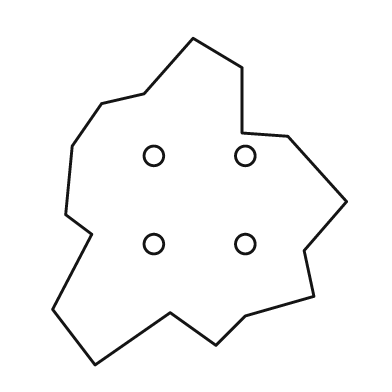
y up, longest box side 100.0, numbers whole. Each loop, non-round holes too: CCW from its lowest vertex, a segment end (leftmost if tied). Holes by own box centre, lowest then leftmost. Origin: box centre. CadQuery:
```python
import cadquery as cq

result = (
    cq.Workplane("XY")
    .moveTo(-32.0, -50.0)
    .lineTo(-9.0, -34.0)
    .lineTo(5.0, -44.0)
    .lineTo(14.0, -35.0)
    .lineTo(35.0, -29.0)
    .lineTo(32.0, -15.0)
    .lineTo(45.0, 0.0)
    .lineTo(27.0, 20.0)
    .lineTo(13.0, 21.0)
    .lineTo(13.0, 41.0)
    .lineTo(-2.0, 50.0)
    .lineTo(-17.0, 33.0)
    .lineTo(-30.0, 30.0)
    .lineTo(-39.0, 17.0)
    .lineTo(-41.0, -4.0)
    .lineTo(-33.0, -10.0)
    .lineTo(-45.0, -33.0)
    .close()
    .moveTo(-14.0, -13.0)
    .circle(3.0)
    .moveTo(14.0, -13.0)
    .circle(3.0)
    .moveTo(-14.0, 14.0)
    .circle(3.0)
    .moveTo(14.0, 14.0)
    .circle(3.0)
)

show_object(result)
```